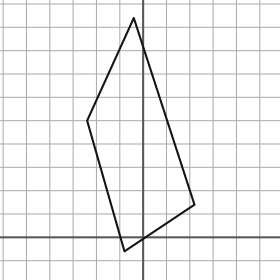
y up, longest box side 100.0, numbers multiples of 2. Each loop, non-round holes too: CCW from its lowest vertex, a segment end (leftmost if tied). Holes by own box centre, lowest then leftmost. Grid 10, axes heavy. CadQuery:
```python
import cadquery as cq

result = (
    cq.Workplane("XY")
    .moveTo(-8.0, -6.0)
    .lineTo(22.0, 14.0)
    .lineTo(-4.0, 94.0)
    .lineTo(-24.0, 50.0)
    .close()
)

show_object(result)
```